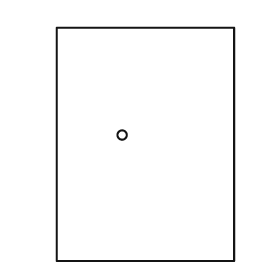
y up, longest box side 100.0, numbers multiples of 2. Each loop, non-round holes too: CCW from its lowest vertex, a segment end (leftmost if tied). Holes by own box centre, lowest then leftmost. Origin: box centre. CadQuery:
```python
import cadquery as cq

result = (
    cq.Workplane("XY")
    .moveTo(-38.0, -50.0)
    .lineTo(38.0, -50.0)
    .lineTo(38.0, 50.0)
    .lineTo(-38.0, 50.0)
    .close()
    .moveTo(-10.0, 4.0)
    .circle(2.0)
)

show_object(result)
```